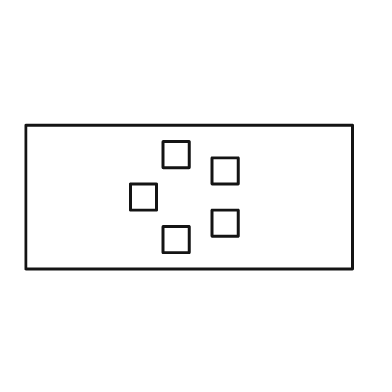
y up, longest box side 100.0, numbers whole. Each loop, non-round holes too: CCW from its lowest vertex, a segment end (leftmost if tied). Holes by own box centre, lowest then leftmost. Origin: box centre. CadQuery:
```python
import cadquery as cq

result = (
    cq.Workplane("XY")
    .moveTo(-50.0, -22.0)
    .lineTo(50.0, -22.0)
    .lineTo(50.0, 22.0)
    .lineTo(-50.0, 22.0)
    .close()
    .moveTo(-8.0, -17.0)
    .lineTo(0.0, -17.0)
    .lineTo(0.0, -9.0)
    .lineTo(-8.0, -9.0)
    .close()
    .moveTo(7.0, -12.0)
    .lineTo(15.0, -12.0)
    .lineTo(15.0, -4.0)
    .lineTo(7.0, -4.0)
    .close()
    .moveTo(-18.0, -4.0)
    .lineTo(-10.0, -4.0)
    .lineTo(-10.0, 4.0)
    .lineTo(-18.0, 4.0)
    .close()
    .moveTo(7.0, 4.0)
    .lineTo(15.0, 4.0)
    .lineTo(15.0, 12.0)
    .lineTo(7.0, 12.0)
    .close()
    .moveTo(-8.0, 9.0)
    .lineTo(0.0, 9.0)
    .lineTo(0.0, 17.0)
    .lineTo(-8.0, 17.0)
    .close()
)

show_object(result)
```